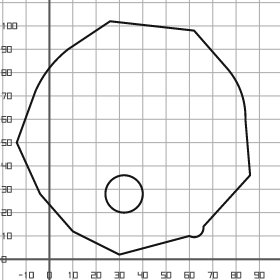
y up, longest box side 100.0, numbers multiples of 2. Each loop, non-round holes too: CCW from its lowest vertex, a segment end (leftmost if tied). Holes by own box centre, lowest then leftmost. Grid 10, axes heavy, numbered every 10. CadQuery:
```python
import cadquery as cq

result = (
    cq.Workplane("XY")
    .moveTo(30.0, 2.0)
    .lineTo(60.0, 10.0)
    .threePointArc((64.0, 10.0), (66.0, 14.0))
    .lineTo(86.0, 36.0)
    .lineTo(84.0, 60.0)
    .threePointArc((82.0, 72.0), (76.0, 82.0))
    .lineTo(62.0, 98.0)
    .lineTo(26.0, 102.0)
    .lineTo(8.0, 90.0)
    .threePointArc((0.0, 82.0), (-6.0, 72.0))
    .lineTo(-14.0, 50.0)
    .lineTo(-4.0, 28.0)
    .lineTo(10.0, 12.0)
    .close()
    .moveTo(32.0, 28.0)
    .circle(8.0)
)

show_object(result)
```